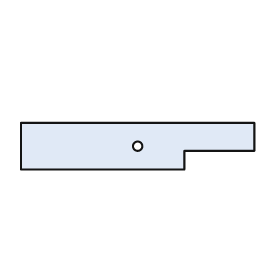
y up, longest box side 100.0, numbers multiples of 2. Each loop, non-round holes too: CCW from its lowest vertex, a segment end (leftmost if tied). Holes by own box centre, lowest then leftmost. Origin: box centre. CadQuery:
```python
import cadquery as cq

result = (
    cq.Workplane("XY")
    .moveTo(-50.0, -10.0)
    .lineTo(20.0, -10.0)
    .lineTo(20.0, -2.0)
    .lineTo(50.0, -2.0)
    .lineTo(50.0, 10.0)
    .lineTo(-50.0, 10.0)
    .close()
    .moveTo(0.0, 0.0)
    .circle(2.0)
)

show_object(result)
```